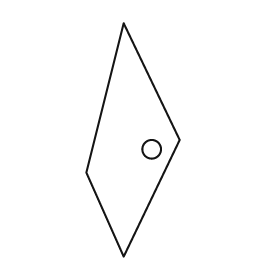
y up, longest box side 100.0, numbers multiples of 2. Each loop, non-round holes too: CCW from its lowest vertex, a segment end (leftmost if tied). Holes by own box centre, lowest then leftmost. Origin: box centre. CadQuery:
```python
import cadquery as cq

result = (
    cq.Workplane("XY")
    .moveTo(-4.0, -50.0)
    .lineTo(20.0, 0.0)
    .lineTo(-4.0, 50.0)
    .lineTo(-20.0, -14.0)
    .close()
    .moveTo(8.0, -4.0)
    .circle(4.0)
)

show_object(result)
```